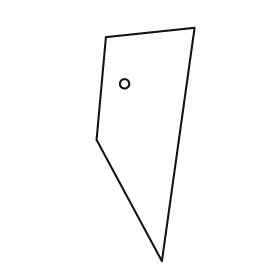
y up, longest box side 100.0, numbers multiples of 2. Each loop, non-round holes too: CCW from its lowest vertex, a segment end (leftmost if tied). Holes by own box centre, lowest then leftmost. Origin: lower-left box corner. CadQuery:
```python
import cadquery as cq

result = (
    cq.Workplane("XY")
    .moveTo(28.0, 0.0)
    .lineTo(42.0, 100.0)
    .lineTo(4.0, 96.0)
    .lineTo(0.0, 52.0)
    .close()
    .moveTo(12.0, 76.0)
    .circle(2.0)
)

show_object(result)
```